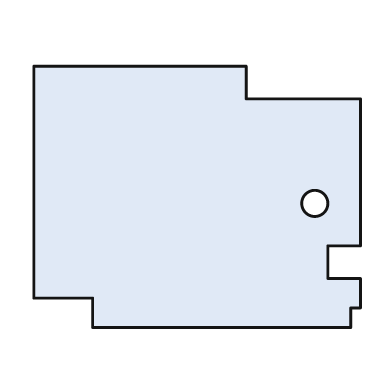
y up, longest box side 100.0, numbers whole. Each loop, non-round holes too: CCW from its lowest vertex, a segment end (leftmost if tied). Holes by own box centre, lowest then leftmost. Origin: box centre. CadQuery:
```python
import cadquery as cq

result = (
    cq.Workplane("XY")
    .moveTo(-32.0, -40.0)
    .lineTo(47.0, -40.0)
    .lineTo(47.0, -34.0)
    .lineTo(50.0, -34.0)
    .lineTo(50.0, -25.0)
    .lineTo(40.0, -25.0)
    .lineTo(40.0, -15.0)
    .lineTo(50.0, -15.0)
    .lineTo(50.0, 30.0)
    .lineTo(15.0, 30.0)
    .lineTo(15.0, 40.0)
    .lineTo(-50.0, 40.0)
    .lineTo(-50.0, -31.0)
    .lineTo(-32.0, -31.0)
    .close()
    .moveTo(36.0, -2.0)
    .circle(4.0)
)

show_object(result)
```